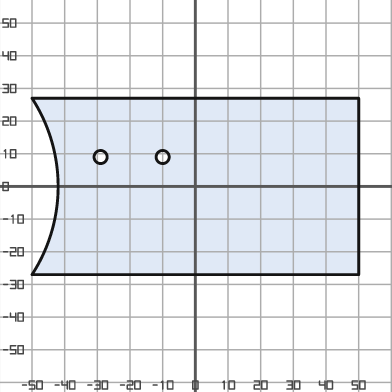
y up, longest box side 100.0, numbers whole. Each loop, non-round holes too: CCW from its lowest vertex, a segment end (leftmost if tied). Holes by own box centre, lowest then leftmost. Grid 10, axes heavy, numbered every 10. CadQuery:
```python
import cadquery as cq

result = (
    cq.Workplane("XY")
    .moveTo(-50.0, -27.0)
    .lineTo(50.0, -27.0)
    .lineTo(50.0, 27.0)
    .lineTo(-50.0, 27.0)
    .threePointArc((-42.0, 0.0), (-50.0, -27.0))
    .close()
    .moveTo(-29.0, 9.0)
    .circle(2.0)
    .moveTo(-10.0, 9.0)
    .circle(2.0)
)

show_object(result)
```